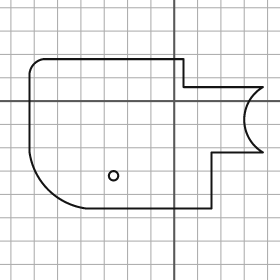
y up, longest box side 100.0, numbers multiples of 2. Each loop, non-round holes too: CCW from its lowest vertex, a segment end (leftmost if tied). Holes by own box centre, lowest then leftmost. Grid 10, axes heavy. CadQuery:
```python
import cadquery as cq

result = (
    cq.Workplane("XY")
    .moveTo(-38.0, -46.0)
    .lineTo(16.0, -46.0)
    .lineTo(16.0, -22.0)
    .lineTo(38.0, -22.0)
    .threePointArc((30.0, -8.0), (38.0, 6.0))
    .lineTo(4.0, 6.0)
    .lineTo(4.0, 18.0)
    .lineTo(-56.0, 18.0)
    .threePointArc((-60.0, 16.0), (-62.0, 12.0))
    .lineTo(-62.0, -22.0)
    .threePointArc((-54.0, -38.0), (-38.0, -46.0))
    .close()
    .moveTo(-26.0, -32.0)
    .circle(2.0)
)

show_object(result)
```